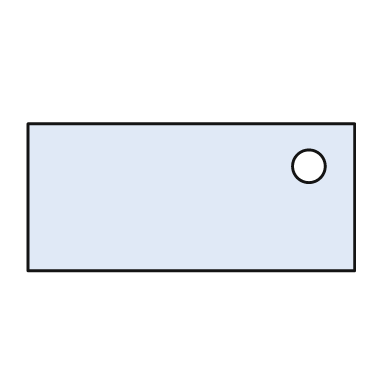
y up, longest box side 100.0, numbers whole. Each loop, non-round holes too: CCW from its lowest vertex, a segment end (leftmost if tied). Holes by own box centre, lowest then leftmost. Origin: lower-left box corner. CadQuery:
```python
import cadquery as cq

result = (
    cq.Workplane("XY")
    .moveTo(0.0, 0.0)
    .lineTo(100.0, 0.0)
    .lineTo(100.0, 45.0)
    .lineTo(0.0, 45.0)
    .close()
    .moveTo(86.0, 32.0)
    .circle(5.0)
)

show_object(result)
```